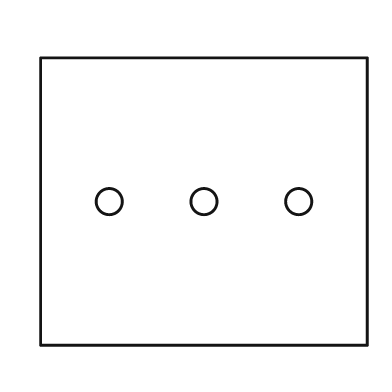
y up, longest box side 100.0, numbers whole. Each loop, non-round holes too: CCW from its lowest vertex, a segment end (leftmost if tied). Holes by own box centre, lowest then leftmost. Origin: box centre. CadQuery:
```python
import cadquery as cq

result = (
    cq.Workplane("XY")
    .moveTo(-50.0, -44.0)
    .lineTo(50.0, -44.0)
    .lineTo(50.0, 44.0)
    .lineTo(-50.0, 44.0)
    .close()
    .moveTo(-29.0, 0.0)
    .circle(4.0)
    .moveTo(0.0, 0.0)
    .circle(4.0)
    .moveTo(29.0, 0.0)
    .circle(4.0)
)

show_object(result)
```